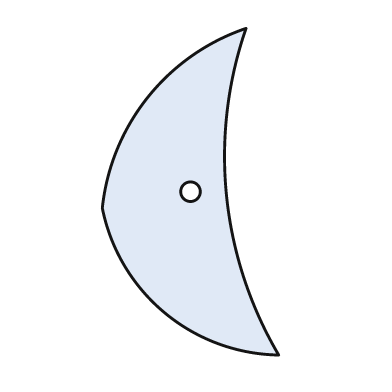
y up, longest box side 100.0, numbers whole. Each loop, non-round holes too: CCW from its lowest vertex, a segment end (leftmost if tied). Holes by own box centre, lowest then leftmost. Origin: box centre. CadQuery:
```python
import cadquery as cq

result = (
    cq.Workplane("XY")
    .moveTo(27.0, -50.0)
    .threePointArc((11.0, -1.0), (17.0, 50.0))
    .threePointArc((-13.0, 29.0), (-27.0, -5.0))
    .threePointArc((-8.0, -37.0), (27.0, -50.0))
    .close()
    .moveTo(0.0, 0.0)
    .circle(3.0)
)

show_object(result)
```